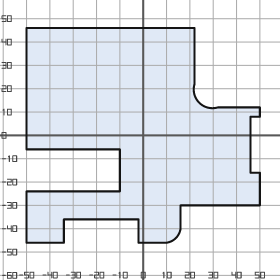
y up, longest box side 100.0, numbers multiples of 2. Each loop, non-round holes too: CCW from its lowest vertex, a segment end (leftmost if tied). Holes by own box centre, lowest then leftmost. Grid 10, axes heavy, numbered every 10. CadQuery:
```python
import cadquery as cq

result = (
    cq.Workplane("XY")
    .moveTo(-50.0, -46.0)
    .lineTo(-34.0, -46.0)
    .lineTo(-34.0, -36.0)
    .lineTo(-2.0, -36.0)
    .lineTo(-2.0, -46.0)
    .lineTo(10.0, -46.0)
    .threePointArc((14.0, -44.0), (16.0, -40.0))
    .lineTo(16.0, -30.0)
    .lineTo(50.0, -30.0)
    .lineTo(50.0, -16.0)
    .lineTo(46.0, -16.0)
    .lineTo(46.0, 8.0)
    .lineTo(50.0, 8.0)
    .lineTo(50.0, 12.0)
    .lineTo(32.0, 12.0)
    .threePointArc((24.0, 14.0), (22.0, 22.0))
    .lineTo(22.0, 46.0)
    .lineTo(-50.0, 46.0)
    .lineTo(-50.0, -6.0)
    .lineTo(-10.0, -6.0)
    .lineTo(-10.0, -24.0)
    .lineTo(-50.0, -24.0)
    .close()
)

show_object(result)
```